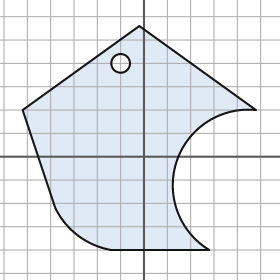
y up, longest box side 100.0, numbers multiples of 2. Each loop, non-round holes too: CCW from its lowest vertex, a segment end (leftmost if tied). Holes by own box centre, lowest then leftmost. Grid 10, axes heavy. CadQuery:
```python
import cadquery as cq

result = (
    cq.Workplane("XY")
    .moveTo(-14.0, -40.0)
    .lineTo(28.0, -40.0)
    .threePointArc((14.0, -2.0), (48.0, 20.0))
    .lineTo(-2.0, 56.0)
    .lineTo(-52.0, 20.0)
    .lineTo(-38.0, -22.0)
    .threePointArc((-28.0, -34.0), (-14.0, -40.0))
    .close()
    .moveTo(-10.0, 40.0)
    .circle(4.0)
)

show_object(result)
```